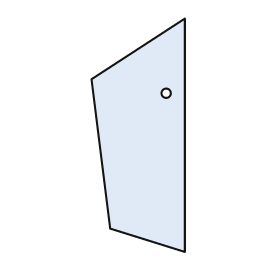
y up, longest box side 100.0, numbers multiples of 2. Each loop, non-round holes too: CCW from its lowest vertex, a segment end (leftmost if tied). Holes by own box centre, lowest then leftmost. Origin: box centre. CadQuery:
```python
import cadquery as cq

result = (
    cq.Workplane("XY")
    .moveTo(20.0, -50.0)
    .lineTo(20.0, 50.0)
    .lineTo(-20.0, 24.0)
    .lineTo(-12.0, -40.0)
    .close()
    .moveTo(12.0, 18.0)
    .circle(2.0)
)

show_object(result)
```